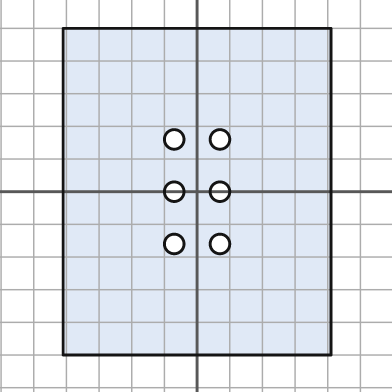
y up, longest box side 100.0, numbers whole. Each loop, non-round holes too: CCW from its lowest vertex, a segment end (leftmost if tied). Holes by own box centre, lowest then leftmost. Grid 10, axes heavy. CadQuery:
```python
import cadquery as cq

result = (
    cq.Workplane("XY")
    .moveTo(-41.0, -50.0)
    .lineTo(41.0, -50.0)
    .lineTo(41.0, 50.0)
    .lineTo(-41.0, 50.0)
    .close()
    .moveTo(-7.0, -16.0)
    .circle(3.0)
    .moveTo(7.0, -16.0)
    .circle(3.0)
    .moveTo(-7.0, 0.0)
    .circle(3.0)
    .moveTo(7.0, 0.0)
    .circle(3.0)
    .moveTo(-7.0, 16.0)
    .circle(3.0)
    .moveTo(7.0, 16.0)
    .circle(3.0)
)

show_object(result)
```